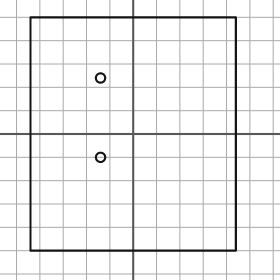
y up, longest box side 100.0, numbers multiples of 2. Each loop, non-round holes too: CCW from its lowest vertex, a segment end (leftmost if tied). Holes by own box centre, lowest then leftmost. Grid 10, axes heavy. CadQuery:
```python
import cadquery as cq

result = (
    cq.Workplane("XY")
    .moveTo(-44.0, -50.0)
    .lineTo(44.0, -50.0)
    .lineTo(44.0, 50.0)
    .lineTo(-44.0, 50.0)
    .close()
    .moveTo(-14.0, -10.0)
    .circle(2.0)
    .moveTo(-14.0, 24.0)
    .circle(2.0)
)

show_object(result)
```